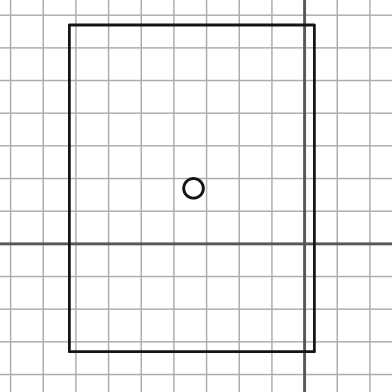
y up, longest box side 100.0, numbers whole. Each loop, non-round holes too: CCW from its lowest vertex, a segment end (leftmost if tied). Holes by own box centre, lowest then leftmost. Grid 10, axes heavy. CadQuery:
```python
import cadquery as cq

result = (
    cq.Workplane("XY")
    .moveTo(-72.0, -33.0)
    .lineTo(3.0, -33.0)
    .lineTo(3.0, 67.0)
    .lineTo(-72.0, 67.0)
    .close()
    .moveTo(-34.0, 17.0)
    .circle(3.0)
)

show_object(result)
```